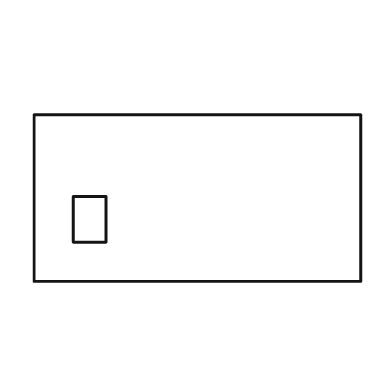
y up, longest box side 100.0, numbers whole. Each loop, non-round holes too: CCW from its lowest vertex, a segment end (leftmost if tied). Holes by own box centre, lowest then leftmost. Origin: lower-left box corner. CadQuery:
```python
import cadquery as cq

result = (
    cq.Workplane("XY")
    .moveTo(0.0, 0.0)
    .lineTo(100.0, 0.0)
    .lineTo(100.0, 51.0)
    .lineTo(0.0, 51.0)
    .close()
    .moveTo(12.0, 12.0)
    .lineTo(22.0, 12.0)
    .lineTo(22.0, 26.0)
    .lineTo(12.0, 26.0)
    .close()
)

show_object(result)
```